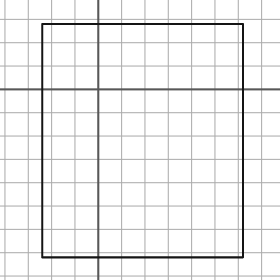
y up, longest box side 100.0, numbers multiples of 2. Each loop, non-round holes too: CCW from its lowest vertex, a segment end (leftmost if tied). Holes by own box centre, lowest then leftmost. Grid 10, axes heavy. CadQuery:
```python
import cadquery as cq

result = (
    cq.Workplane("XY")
    .moveTo(-24.0, -72.0)
    .lineTo(62.0, -72.0)
    .lineTo(62.0, 28.0)
    .lineTo(-24.0, 28.0)
    .close()
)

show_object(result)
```